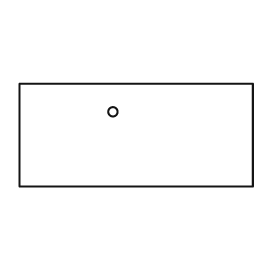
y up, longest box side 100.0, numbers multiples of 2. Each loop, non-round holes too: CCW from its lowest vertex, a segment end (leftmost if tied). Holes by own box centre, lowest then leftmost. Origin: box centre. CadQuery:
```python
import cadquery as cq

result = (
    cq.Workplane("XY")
    .moveTo(-50.0, -22.0)
    .lineTo(50.0, -22.0)
    .lineTo(50.0, 22.0)
    .lineTo(-50.0, 22.0)
    .close()
    .moveTo(-10.0, 10.0)
    .circle(2.0)
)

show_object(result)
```